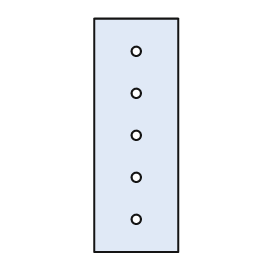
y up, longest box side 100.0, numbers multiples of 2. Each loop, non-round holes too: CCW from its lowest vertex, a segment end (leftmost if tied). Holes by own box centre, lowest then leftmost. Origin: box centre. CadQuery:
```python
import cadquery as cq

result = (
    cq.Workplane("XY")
    .moveTo(-18.0, -50.0)
    .lineTo(18.0, -50.0)
    .lineTo(18.0, 50.0)
    .lineTo(-18.0, 50.0)
    .close()
    .moveTo(0.0, -36.0)
    .circle(2.0)
    .moveTo(0.0, -18.0)
    .circle(2.0)
    .moveTo(0.0, 0.0)
    .circle(2.0)
    .moveTo(0.0, 18.0)
    .circle(2.0)
    .moveTo(0.0, 36.0)
    .circle(2.0)
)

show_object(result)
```